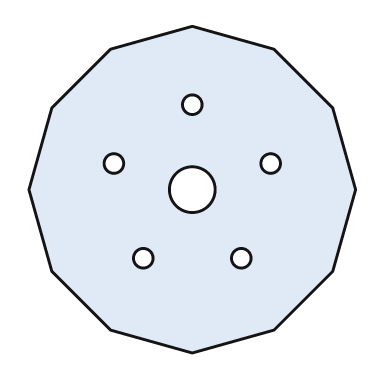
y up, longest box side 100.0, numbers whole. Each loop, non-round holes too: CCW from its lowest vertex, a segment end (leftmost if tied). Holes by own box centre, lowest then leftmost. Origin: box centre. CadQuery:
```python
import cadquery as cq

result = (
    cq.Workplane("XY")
    .moveTo(0.0, -50.0)
    .lineTo(25.0, -43.0)
    .lineTo(43.0, -25.0)
    .lineTo(50.0, 0.0)
    .lineTo(43.0, 25.0)
    .lineTo(25.0, 43.0)
    .lineTo(0.0, 50.0)
    .lineTo(-25.0, 43.0)
    .lineTo(-43.0, 25.0)
    .lineTo(-50.0, 0.0)
    .lineTo(-43.0, -25.0)
    .lineTo(-25.0, -43.0)
    .close()
    .moveTo(-15.0, -21.0)
    .circle(3.0)
    .moveTo(15.0, -21.0)
    .circle(3.0)
    .moveTo(0.0, 0.0)
    .circle(7.0)
    .moveTo(-24.0, 8.0)
    .circle(3.0)
    .moveTo(24.0, 8.0)
    .circle(3.0)
    .moveTo(0.0, 26.0)
    .circle(3.0)
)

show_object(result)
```